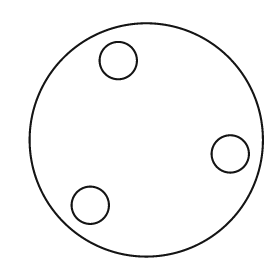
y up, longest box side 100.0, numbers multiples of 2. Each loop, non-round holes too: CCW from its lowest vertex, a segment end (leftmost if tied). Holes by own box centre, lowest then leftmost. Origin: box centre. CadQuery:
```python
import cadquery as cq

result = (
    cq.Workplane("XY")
    .moveTo(0.0, 0.0)
    .circle(50.0)
    .moveTo(-24.0, -28.0)
    .circle(8.0)
    .moveTo(36.0, -6.0)
    .circle(8.0)
    .moveTo(-12.0, 34.0)
    .circle(8.0)
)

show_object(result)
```